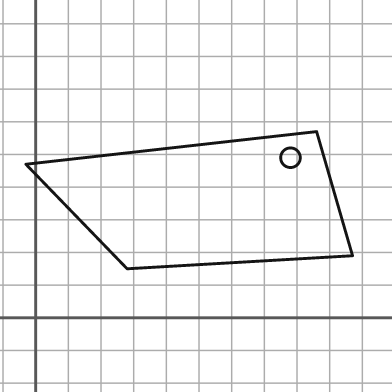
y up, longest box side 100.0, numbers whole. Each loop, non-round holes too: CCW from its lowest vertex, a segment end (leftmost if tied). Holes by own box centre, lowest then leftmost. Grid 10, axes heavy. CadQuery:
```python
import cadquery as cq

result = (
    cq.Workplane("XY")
    .moveTo(28.0, 15.0)
    .lineTo(97.0, 19.0)
    .lineTo(86.0, 57.0)
    .lineTo(-3.0, 47.0)
    .close()
    .moveTo(78.0, 49.0)
    .circle(3.0)
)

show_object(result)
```